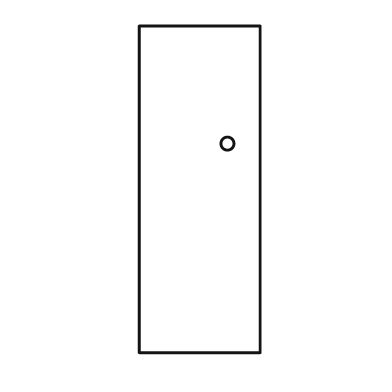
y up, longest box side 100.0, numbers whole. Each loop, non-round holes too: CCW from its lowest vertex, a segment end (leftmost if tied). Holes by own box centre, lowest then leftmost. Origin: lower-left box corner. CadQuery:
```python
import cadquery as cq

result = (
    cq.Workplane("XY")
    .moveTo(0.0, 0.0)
    .lineTo(37.0, 0.0)
    .lineTo(37.0, 100.0)
    .lineTo(0.0, 100.0)
    .close()
    .moveTo(27.0, 64.0)
    .circle(2.0)
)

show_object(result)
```